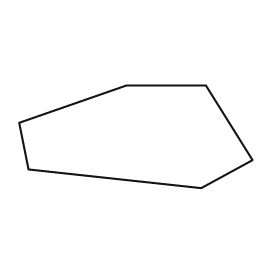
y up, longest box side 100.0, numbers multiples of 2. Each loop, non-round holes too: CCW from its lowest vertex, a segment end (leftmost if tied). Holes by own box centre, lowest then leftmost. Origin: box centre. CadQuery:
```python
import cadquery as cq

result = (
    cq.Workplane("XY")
    .moveTo(28.0, -22.0)
    .lineTo(50.0, -10.0)
    .lineTo(30.0, 22.0)
    .lineTo(-4.0, 22.0)
    .lineTo(-50.0, 6.0)
    .lineTo(-46.0, -14.0)
    .close()
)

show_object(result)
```